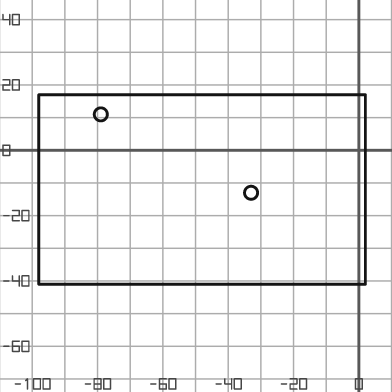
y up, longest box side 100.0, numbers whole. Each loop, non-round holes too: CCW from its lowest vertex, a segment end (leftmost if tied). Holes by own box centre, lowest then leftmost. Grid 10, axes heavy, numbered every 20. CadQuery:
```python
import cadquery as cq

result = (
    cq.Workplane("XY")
    .moveTo(-98.0, -41.0)
    .lineTo(2.0, -41.0)
    .lineTo(2.0, 17.0)
    .lineTo(-98.0, 17.0)
    .close()
    .moveTo(-33.0, -13.0)
    .circle(2.0)
    .moveTo(-79.0, 11.0)
    .circle(2.0)
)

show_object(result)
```